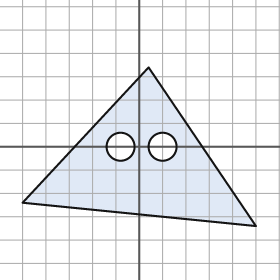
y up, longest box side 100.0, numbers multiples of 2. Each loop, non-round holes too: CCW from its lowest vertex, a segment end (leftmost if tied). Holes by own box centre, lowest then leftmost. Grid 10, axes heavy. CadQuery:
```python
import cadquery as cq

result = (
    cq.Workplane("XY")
    .moveTo(50.0, -34.0)
    .lineTo(4.0, 34.0)
    .lineTo(-50.0, -24.0)
    .close()
    .moveTo(-8.0, 0.0)
    .circle(6.0)
    .moveTo(10.0, 0.0)
    .circle(6.0)
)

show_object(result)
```